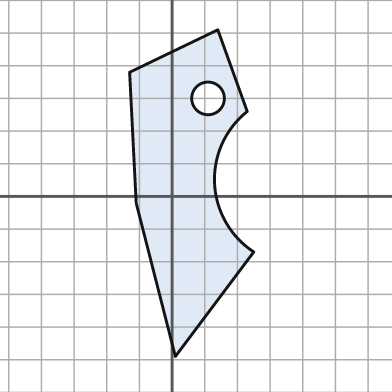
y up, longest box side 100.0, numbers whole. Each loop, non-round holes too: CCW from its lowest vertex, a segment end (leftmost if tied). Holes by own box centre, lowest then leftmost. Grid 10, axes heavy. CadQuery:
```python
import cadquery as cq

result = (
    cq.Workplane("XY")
    .moveTo(1.0, -49.0)
    .lineTo(25.0, -17.0)
    .threePointArc((13.0, 4.0), (23.0, 26.0))
    .lineTo(14.0, 51.0)
    .lineTo(-13.0, 38.0)
    .lineTo(-11.0, -2.0)
    .close()
    .moveTo(11.0, 30.0)
    .circle(5.0)
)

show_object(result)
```